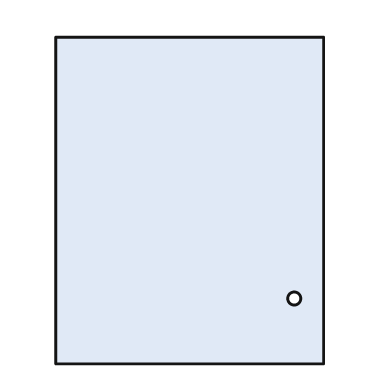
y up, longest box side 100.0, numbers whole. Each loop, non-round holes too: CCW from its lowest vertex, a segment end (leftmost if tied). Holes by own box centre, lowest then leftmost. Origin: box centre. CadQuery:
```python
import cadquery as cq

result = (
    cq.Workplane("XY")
    .moveTo(-41.0, -50.0)
    .lineTo(41.0, -50.0)
    .lineTo(41.0, 50.0)
    .lineTo(-41.0, 50.0)
    .close()
    .moveTo(32.0, -30.0)
    .circle(2.0)
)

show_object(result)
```